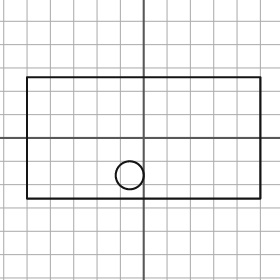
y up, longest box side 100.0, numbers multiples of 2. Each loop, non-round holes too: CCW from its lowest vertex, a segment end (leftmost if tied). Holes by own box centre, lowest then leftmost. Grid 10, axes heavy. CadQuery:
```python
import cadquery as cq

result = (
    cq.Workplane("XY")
    .moveTo(-50.0, -26.0)
    .lineTo(50.0, -26.0)
    .lineTo(50.0, 26.0)
    .lineTo(-50.0, 26.0)
    .close()
    .moveTo(-6.0, -16.0)
    .circle(6.0)
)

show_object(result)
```